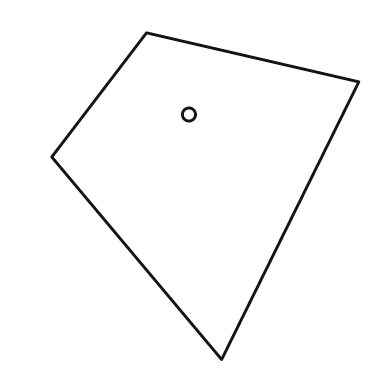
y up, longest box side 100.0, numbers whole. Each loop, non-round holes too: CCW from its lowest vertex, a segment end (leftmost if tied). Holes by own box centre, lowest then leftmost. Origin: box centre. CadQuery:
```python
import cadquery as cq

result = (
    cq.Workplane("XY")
    .moveTo(5.0, -50.0)
    .lineTo(47.0, 35.0)
    .lineTo(-18.0, 50.0)
    .lineTo(-47.0, 12.0)
    .close()
    .moveTo(-5.0, 25.0)
    .circle(2.0)
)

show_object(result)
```